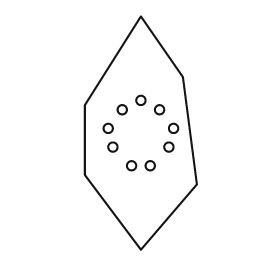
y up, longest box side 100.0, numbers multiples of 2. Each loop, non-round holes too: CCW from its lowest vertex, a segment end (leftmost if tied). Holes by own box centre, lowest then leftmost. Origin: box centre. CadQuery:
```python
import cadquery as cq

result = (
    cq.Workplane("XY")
    .moveTo(0.0, -50.0)
    .lineTo(24.0, -22.0)
    .lineTo(18.0, 24.0)
    .lineTo(0.0, 50.0)
    .lineTo(-24.0, 12.0)
    .lineTo(-24.0, -18.0)
    .close()
    .moveTo(-4.0, -14.0)
    .circle(2.0)
    .moveTo(4.0, -14.0)
    .circle(2.0)
    .moveTo(-12.0, -6.0)
    .circle(2.0)
    .moveTo(12.0, -6.0)
    .circle(2.0)
    .moveTo(-14.0, 2.0)
    .circle(2.0)
    .moveTo(14.0, 2.0)
    .circle(2.0)
    .moveTo(-8.0, 10.0)
    .circle(2.0)
    .moveTo(8.0, 10.0)
    .circle(2.0)
    .moveTo(0.0, 14.0)
    .circle(2.0)
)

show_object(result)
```